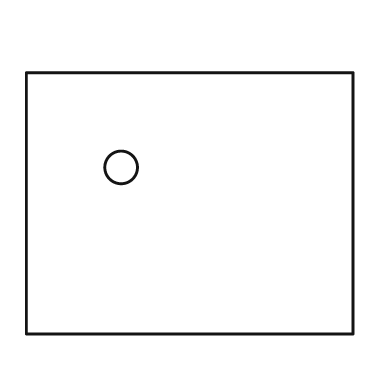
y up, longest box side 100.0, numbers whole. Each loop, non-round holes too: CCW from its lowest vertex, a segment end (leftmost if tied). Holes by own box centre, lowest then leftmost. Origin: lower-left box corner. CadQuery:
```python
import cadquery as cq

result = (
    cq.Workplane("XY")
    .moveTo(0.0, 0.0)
    .lineTo(100.0, 0.0)
    .lineTo(100.0, 80.0)
    .lineTo(0.0, 80.0)
    .close()
    .moveTo(29.0, 51.0)
    .circle(5.0)
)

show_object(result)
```